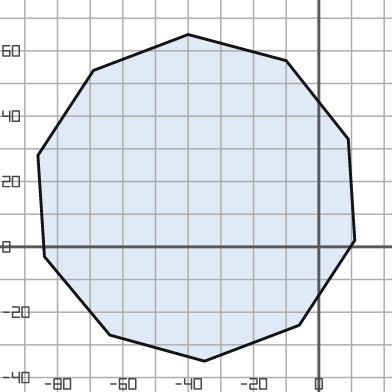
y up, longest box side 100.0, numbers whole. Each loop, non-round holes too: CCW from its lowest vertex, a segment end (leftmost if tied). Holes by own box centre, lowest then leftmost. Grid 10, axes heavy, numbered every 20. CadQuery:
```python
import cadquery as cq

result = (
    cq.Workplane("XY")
    .moveTo(-35.0, -35.0)
    .lineTo(-6.0, -24.0)
    .lineTo(11.0, 2.0)
    .lineTo(9.0, 33.0)
    .lineTo(-10.0, 57.0)
    .lineTo(-40.0, 65.0)
    .lineTo(-69.0, 54.0)
    .lineTo(-86.0, 28.0)
    .lineTo(-84.0, -3.0)
    .lineTo(-64.0, -27.0)
    .close()
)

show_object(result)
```